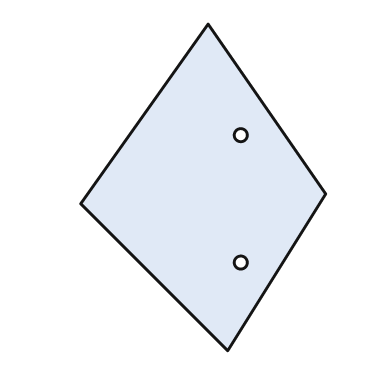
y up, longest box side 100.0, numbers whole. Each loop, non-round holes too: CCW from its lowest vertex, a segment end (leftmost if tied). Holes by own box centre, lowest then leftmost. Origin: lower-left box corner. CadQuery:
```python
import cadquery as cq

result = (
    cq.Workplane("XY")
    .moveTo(45.0, 0.0)
    .lineTo(75.0, 48.0)
    .lineTo(39.0, 100.0)
    .lineTo(0.0, 45.0)
    .close()
    .moveTo(49.0, 27.0)
    .circle(2.0)
    .moveTo(49.0, 66.0)
    .circle(2.0)
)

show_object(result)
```